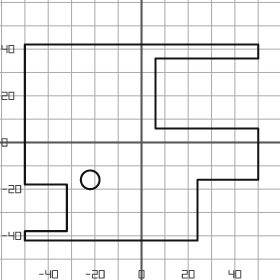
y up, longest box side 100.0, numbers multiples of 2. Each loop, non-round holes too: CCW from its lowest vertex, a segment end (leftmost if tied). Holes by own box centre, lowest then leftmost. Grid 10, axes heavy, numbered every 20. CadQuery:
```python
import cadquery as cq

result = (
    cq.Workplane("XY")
    .moveTo(-50.0, -42.0)
    .lineTo(24.0, -42.0)
    .lineTo(24.0, -16.0)
    .lineTo(50.0, -16.0)
    .lineTo(50.0, 6.0)
    .lineTo(6.0, 6.0)
    .lineTo(6.0, 36.0)
    .lineTo(50.0, 36.0)
    .lineTo(50.0, 42.0)
    .lineTo(-50.0, 42.0)
    .lineTo(-50.0, -18.0)
    .lineTo(-32.0, -18.0)
    .lineTo(-32.0, -38.0)
    .lineTo(-50.0, -38.0)
    .close()
    .moveTo(-22.0, -16.0)
    .circle(4.0)
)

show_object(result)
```